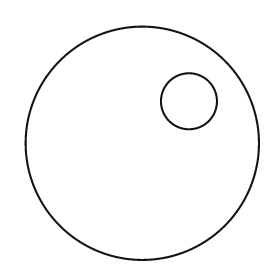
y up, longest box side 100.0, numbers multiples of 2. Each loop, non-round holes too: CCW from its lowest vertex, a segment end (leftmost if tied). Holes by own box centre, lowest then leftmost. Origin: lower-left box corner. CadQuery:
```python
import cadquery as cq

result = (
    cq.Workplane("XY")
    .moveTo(50.0, 50.0)
    .circle(50.0)
    .moveTo(70.0, 68.0)
    .circle(12.0)
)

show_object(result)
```